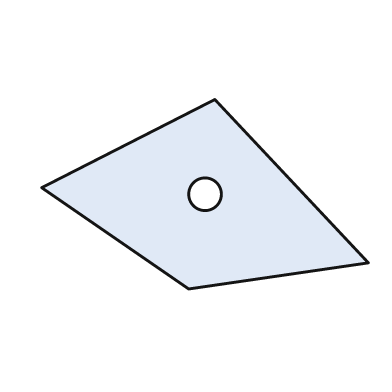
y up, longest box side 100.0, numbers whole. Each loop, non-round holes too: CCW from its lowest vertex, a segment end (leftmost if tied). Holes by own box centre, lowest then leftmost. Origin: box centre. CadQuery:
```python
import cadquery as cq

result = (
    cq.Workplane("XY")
    .moveTo(-5.0, -29.0)
    .lineTo(50.0, -21.0)
    .lineTo(3.0, 29.0)
    .lineTo(-50.0, 2.0)
    .close()
    .moveTo(0.0, 0.0)
    .circle(5.0)
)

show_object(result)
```